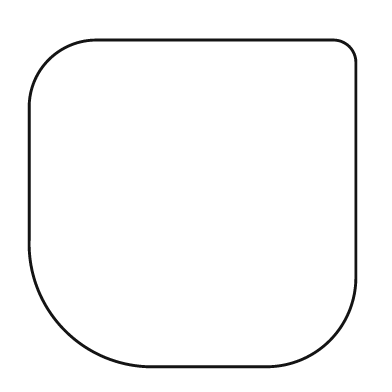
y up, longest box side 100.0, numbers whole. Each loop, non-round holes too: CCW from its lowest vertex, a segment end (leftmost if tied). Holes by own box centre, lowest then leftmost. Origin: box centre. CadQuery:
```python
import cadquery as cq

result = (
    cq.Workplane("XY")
    .moveTo(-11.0, -50.0)
    .lineTo(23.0, -50.0)
    .threePointArc((42.0, -42.0), (50.0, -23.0))
    .lineTo(50.0, 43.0)
    .threePointArc((48.0, 48.0), (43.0, 50.0))
    .lineTo(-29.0, 50.0)
    .threePointArc((-44.0, 44.0), (-50.0, 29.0))
    .lineTo(-50.0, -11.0)
    .threePointArc((-39.0, -39.0), (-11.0, -50.0))
    .close()
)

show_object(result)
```